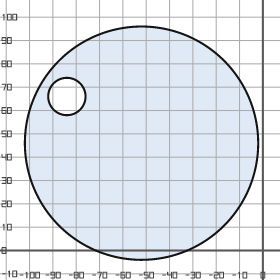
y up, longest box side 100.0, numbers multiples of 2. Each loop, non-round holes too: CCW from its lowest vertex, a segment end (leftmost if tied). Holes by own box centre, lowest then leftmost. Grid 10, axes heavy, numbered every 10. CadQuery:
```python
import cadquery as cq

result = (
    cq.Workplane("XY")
    .moveTo(-52.0, 46.0)
    .circle(50.0)
    .moveTo(-84.0, 66.0)
    .circle(8.0)
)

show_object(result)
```